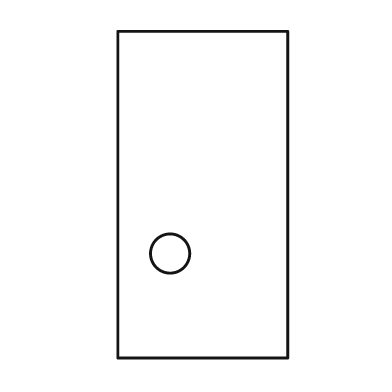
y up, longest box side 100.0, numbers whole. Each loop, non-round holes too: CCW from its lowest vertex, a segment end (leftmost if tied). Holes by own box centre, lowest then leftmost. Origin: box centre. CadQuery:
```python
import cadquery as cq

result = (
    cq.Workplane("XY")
    .moveTo(-26.0, -50.0)
    .lineTo(26.0, -50.0)
    .lineTo(26.0, 50.0)
    .lineTo(-26.0, 50.0)
    .close()
    .moveTo(-10.0, -18.0)
    .circle(6.0)
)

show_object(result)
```